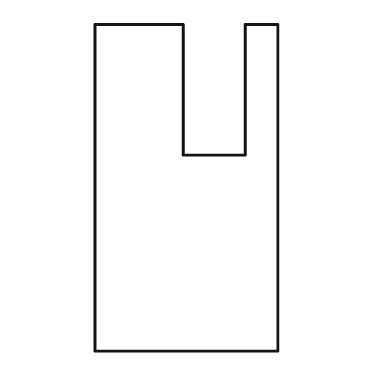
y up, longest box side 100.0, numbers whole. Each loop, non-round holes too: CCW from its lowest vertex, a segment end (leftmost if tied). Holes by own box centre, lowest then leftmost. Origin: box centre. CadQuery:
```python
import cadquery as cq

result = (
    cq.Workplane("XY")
    .moveTo(-28.0, -50.0)
    .lineTo(28.0, -50.0)
    .lineTo(28.0, 50.0)
    .lineTo(18.0, 50.0)
    .lineTo(18.0, 10.0)
    .lineTo(-1.0, 10.0)
    .lineTo(-1.0, 50.0)
    .lineTo(-28.0, 50.0)
    .close()
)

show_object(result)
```